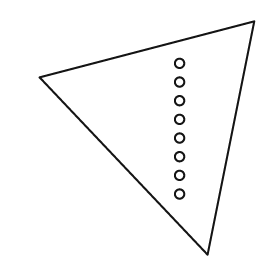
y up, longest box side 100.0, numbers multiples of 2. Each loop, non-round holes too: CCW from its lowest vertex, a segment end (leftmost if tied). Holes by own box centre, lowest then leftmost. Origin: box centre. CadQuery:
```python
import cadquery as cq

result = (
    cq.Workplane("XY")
    .moveTo(26.0, -50.0)
    .lineTo(46.0, 50.0)
    .lineTo(-46.0, 26.0)
    .close()
    .moveTo(14.0, -24.0)
    .circle(2.0)
    .moveTo(14.0, -16.0)
    .circle(2.0)
    .moveTo(14.0, -8.0)
    .circle(2.0)
    .moveTo(14.0, 0.0)
    .circle(2.0)
    .moveTo(14.0, 8.0)
    .circle(2.0)
    .moveTo(14.0, 16.0)
    .circle(2.0)
    .moveTo(14.0, 24.0)
    .circle(2.0)
    .moveTo(14.0, 32.0)
    .circle(2.0)
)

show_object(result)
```